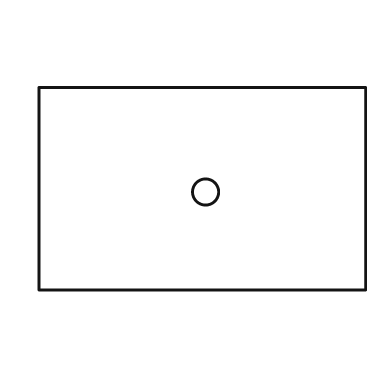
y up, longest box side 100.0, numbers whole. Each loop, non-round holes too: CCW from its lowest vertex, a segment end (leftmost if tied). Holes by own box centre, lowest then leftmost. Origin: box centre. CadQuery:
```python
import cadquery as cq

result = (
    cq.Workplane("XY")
    .moveTo(-50.0, -31.0)
    .lineTo(50.0, -31.0)
    .lineTo(50.0, 31.0)
    .lineTo(-50.0, 31.0)
    .close()
    .moveTo(1.0, -1.0)
    .circle(4.0)
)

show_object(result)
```